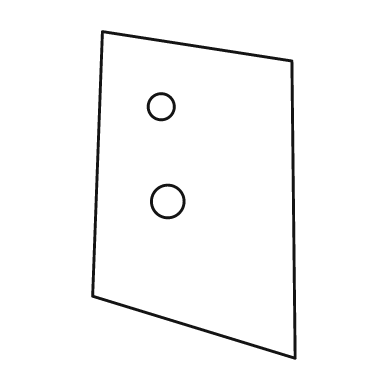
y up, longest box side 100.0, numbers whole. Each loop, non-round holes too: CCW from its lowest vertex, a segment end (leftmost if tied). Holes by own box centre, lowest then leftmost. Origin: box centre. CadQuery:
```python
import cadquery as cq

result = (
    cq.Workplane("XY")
    .moveTo(31.0, -50.0)
    .lineTo(30.0, 41.0)
    .lineTo(-28.0, 50.0)
    .lineTo(-31.0, -31.0)
    .close()
    .moveTo(-8.0, -2.0)
    .circle(5.0)
    .moveTo(-10.0, 27.0)
    .circle(4.0)
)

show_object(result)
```